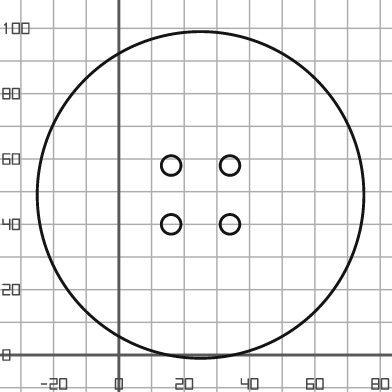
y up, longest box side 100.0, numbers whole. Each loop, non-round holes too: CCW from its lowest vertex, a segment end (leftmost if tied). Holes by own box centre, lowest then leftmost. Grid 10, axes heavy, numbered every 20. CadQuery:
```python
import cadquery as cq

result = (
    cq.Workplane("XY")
    .moveTo(25.0, 49.0)
    .circle(50.0)
    .moveTo(16.0, 40.0)
    .circle(3.0)
    .moveTo(34.0, 40.0)
    .circle(3.0)
    .moveTo(16.0, 58.0)
    .circle(3.0)
    .moveTo(34.0, 58.0)
    .circle(3.0)
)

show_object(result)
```